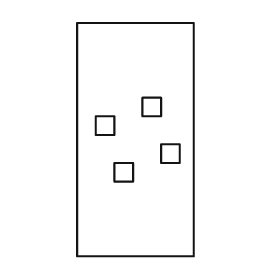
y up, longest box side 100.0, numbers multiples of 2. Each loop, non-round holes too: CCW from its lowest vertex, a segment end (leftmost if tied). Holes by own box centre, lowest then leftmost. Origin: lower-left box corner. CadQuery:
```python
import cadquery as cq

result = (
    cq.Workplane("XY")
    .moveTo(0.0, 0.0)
    .lineTo(50.0, 0.0)
    .lineTo(50.0, 100.0)
    .lineTo(0.0, 100.0)
    .close()
    .moveTo(16.0, 32.0)
    .lineTo(24.0, 32.0)
    .lineTo(24.0, 40.0)
    .lineTo(16.0, 40.0)
    .close()
    .moveTo(36.0, 40.0)
    .lineTo(44.0, 40.0)
    .lineTo(44.0, 48.0)
    .lineTo(36.0, 48.0)
    .close()
    .moveTo(8.0, 52.0)
    .lineTo(16.0, 52.0)
    .lineTo(16.0, 60.0)
    .lineTo(8.0, 60.0)
    .close()
    .moveTo(28.0, 60.0)
    .lineTo(36.0, 60.0)
    .lineTo(36.0, 68.0)
    .lineTo(28.0, 68.0)
    .close()
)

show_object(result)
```